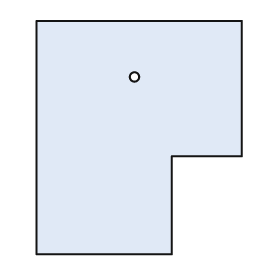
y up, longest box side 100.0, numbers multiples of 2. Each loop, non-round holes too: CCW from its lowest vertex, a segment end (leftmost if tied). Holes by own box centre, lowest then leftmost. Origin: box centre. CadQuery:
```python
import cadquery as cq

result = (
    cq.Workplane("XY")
    .moveTo(-44.0, -50.0)
    .lineTo(14.0, -50.0)
    .lineTo(14.0, -8.0)
    .lineTo(44.0, -8.0)
    .lineTo(44.0, 50.0)
    .lineTo(-44.0, 50.0)
    .close()
    .moveTo(-2.0, 26.0)
    .circle(2.0)
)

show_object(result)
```